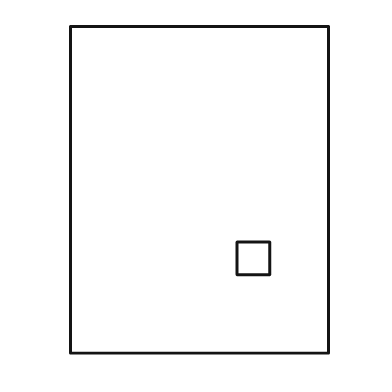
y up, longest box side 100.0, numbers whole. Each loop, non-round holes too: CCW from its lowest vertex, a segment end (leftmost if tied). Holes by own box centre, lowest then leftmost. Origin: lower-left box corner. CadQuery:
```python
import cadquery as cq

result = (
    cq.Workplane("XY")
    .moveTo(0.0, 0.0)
    .lineTo(79.0, 0.0)
    .lineTo(79.0, 100.0)
    .lineTo(0.0, 100.0)
    .close()
    .moveTo(51.0, 24.0)
    .lineTo(61.0, 24.0)
    .lineTo(61.0, 34.0)
    .lineTo(51.0, 34.0)
    .close()
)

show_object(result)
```